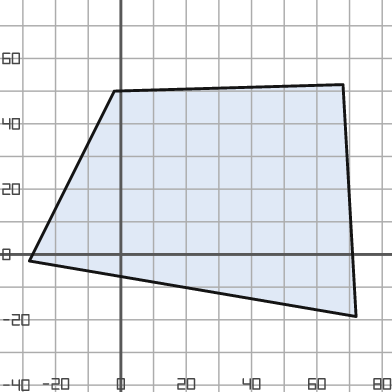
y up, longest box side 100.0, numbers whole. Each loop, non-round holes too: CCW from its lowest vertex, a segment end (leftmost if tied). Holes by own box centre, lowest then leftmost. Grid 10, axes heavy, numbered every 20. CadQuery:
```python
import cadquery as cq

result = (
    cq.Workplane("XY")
    .moveTo(72.0, -19.0)
    .lineTo(68.0, 52.0)
    .lineTo(-2.0, 50.0)
    .lineTo(-28.0, -2.0)
    .close()
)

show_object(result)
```